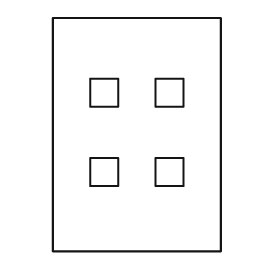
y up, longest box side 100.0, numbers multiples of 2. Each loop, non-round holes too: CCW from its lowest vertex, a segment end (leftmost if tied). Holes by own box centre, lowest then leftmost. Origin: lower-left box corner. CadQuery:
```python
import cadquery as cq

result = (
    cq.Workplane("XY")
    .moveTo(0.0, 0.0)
    .lineTo(72.0, 0.0)
    .lineTo(72.0, 100.0)
    .lineTo(0.0, 100.0)
    .close()
    .moveTo(16.0, 28.0)
    .lineTo(28.0, 28.0)
    .lineTo(28.0, 40.0)
    .lineTo(16.0, 40.0)
    .close()
    .moveTo(44.0, 28.0)
    .lineTo(56.0, 28.0)
    .lineTo(56.0, 40.0)
    .lineTo(44.0, 40.0)
    .close()
    .moveTo(16.0, 62.0)
    .lineTo(28.0, 62.0)
    .lineTo(28.0, 74.0)
    .lineTo(16.0, 74.0)
    .close()
    .moveTo(44.0, 62.0)
    .lineTo(56.0, 62.0)
    .lineTo(56.0, 74.0)
    .lineTo(44.0, 74.0)
    .close()
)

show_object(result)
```